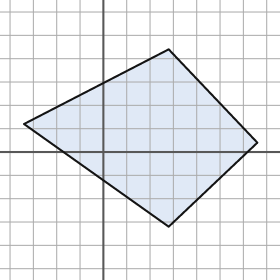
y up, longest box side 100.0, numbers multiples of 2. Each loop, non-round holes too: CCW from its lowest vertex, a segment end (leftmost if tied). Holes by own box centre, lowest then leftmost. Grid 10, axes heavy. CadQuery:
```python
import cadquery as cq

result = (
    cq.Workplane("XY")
    .moveTo(28.0, -32.0)
    .lineTo(66.0, 4.0)
    .lineTo(28.0, 44.0)
    .lineTo(-34.0, 12.0)
    .close()
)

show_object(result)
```